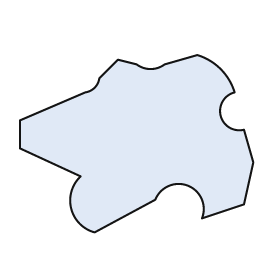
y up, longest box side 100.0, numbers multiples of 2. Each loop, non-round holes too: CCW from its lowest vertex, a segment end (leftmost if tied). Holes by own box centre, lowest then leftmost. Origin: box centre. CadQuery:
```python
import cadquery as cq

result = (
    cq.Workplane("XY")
    .moveTo(-18.0, -38.0)
    .lineTo(8.0, -24.0)
    .threePointArc((22.0, -18.0), (28.0, -32.0))
    .lineTo(46.0, -26.0)
    .lineTo(50.0, -8.0)
    .lineTo(46.0, 6.0)
    .threePointArc((36.0, 12.0), (42.0, 22.0))
    .threePointArc((36.0, 32.0), (26.0, 38.0))
    .lineTo(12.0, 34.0)
    .threePointArc((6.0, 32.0), (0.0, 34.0))
    .lineTo(-8.0, 36.0)
    .lineTo(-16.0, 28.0)
    .threePointArc((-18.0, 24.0), (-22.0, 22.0))
    .lineTo(-50.0, 10.0)
    .lineTo(-50.0, -2.0)
    .lineTo(-24.0, -14.0)
    .threePointArc((-28.0, -28.0), (-18.0, -38.0))
    .close()
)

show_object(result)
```